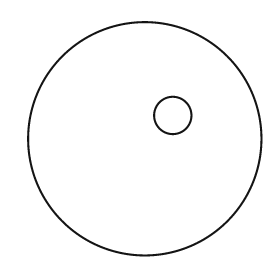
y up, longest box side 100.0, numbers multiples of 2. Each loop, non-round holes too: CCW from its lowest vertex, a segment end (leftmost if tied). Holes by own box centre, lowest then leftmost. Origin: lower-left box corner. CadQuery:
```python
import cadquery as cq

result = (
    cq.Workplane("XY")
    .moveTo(50.0, 50.0)
    .circle(50.0)
    .moveTo(62.0, 60.0)
    .circle(8.0)
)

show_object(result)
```